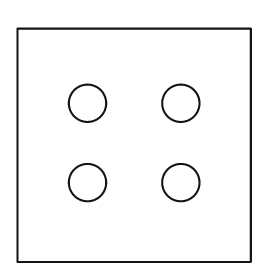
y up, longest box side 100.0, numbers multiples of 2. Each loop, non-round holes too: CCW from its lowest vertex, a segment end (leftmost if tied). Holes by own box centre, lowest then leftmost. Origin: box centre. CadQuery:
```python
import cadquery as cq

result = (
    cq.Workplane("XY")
    .moveTo(-50.0, -50.0)
    .lineTo(50.0, -50.0)
    .lineTo(50.0, 50.0)
    .lineTo(-50.0, 50.0)
    .close()
    .moveTo(-20.0, -16.0)
    .circle(8.0)
    .moveTo(20.0, -16.0)
    .circle(8.0)
    .moveTo(-20.0, 18.0)
    .circle(8.0)
    .moveTo(20.0, 18.0)
    .circle(8.0)
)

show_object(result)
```